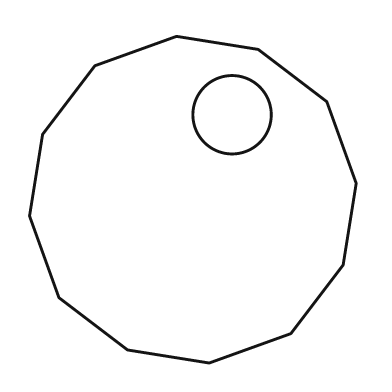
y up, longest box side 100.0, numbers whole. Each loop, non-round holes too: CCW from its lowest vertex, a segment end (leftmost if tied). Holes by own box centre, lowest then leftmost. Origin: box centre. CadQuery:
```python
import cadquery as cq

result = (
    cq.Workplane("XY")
    .moveTo(5.0, -50.0)
    .lineTo(30.0, -41.0)
    .lineTo(46.0, -20.0)
    .lineTo(50.0, 5.0)
    .lineTo(41.0, 30.0)
    .lineTo(20.0, 46.0)
    .lineTo(-5.0, 50.0)
    .lineTo(-30.0, 41.0)
    .lineTo(-46.0, 20.0)
    .lineTo(-50.0, -5.0)
    .lineTo(-41.0, -30.0)
    .lineTo(-20.0, -46.0)
    .close()
    .moveTo(12.0, 26.0)
    .circle(12.0)
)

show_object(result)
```